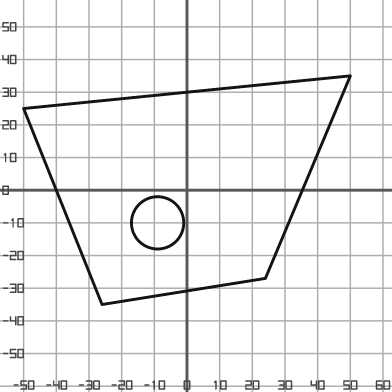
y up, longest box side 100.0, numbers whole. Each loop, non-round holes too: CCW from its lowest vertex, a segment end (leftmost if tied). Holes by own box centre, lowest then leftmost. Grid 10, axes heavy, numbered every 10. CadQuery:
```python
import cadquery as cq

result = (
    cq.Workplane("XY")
    .moveTo(-26.0, -35.0)
    .lineTo(24.0, -27.0)
    .lineTo(50.0, 35.0)
    .lineTo(-50.0, 25.0)
    .close()
    .moveTo(-9.0, -10.0)
    .circle(8.0)
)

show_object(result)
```